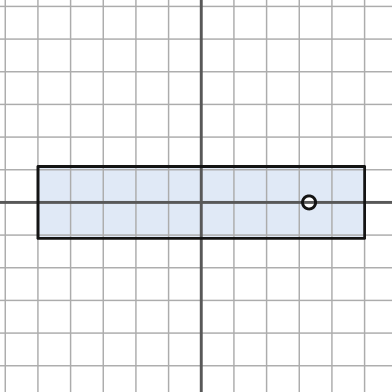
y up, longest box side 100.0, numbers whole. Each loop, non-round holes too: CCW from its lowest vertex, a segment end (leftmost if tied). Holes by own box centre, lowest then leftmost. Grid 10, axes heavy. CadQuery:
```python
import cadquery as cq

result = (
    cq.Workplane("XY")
    .moveTo(-50.0, -11.0)
    .lineTo(50.0, -11.0)
    .lineTo(50.0, 11.0)
    .lineTo(-50.0, 11.0)
    .close()
    .moveTo(33.0, 0.0)
    .circle(2.0)
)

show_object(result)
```